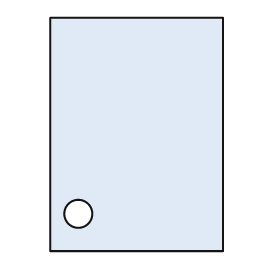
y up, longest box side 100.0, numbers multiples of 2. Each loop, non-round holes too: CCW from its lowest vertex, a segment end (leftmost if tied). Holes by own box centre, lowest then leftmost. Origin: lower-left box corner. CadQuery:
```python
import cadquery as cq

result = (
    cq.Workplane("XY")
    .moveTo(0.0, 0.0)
    .lineTo(74.0, 0.0)
    .lineTo(74.0, 100.0)
    .lineTo(0.0, 100.0)
    .close()
    .moveTo(12.0, 16.0)
    .circle(6.0)
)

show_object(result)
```